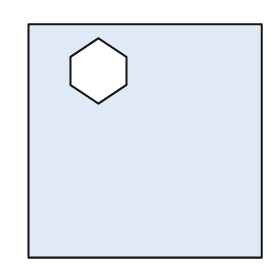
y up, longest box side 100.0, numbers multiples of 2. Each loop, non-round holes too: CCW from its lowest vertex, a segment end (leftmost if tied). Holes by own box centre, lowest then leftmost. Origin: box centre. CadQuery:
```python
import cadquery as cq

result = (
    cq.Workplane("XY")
    .moveTo(-50.0, -50.0)
    .lineTo(50.0, -50.0)
    .lineTo(50.0, 50.0)
    .lineTo(-50.0, 50.0)
    .close()
    .moveTo(-20.0, 16.0)
    .lineTo(-8.0, 24.0)
    .lineTo(-8.0, 36.0)
    .lineTo(-20.0, 44.0)
    .lineTo(-32.0, 36.0)
    .lineTo(-32.0, 24.0)
    .close()
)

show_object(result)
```